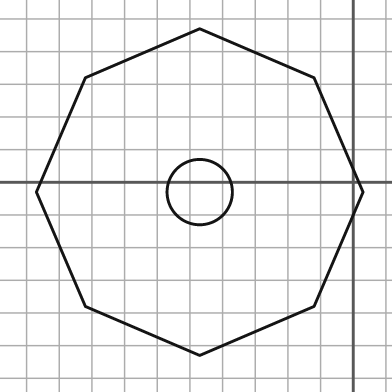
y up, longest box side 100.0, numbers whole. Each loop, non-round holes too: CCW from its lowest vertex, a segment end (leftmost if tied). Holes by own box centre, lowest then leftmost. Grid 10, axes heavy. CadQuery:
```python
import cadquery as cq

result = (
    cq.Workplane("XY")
    .moveTo(-47.0, -53.0)
    .lineTo(-12.0, -38.0)
    .lineTo(3.0, -3.0)
    .lineTo(-12.0, 32.0)
    .lineTo(-47.0, 47.0)
    .lineTo(-82.0, 32.0)
    .lineTo(-97.0, -3.0)
    .lineTo(-82.0, -38.0)
    .close()
    .moveTo(-47.0, -3.0)
    .circle(10.0)
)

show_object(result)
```